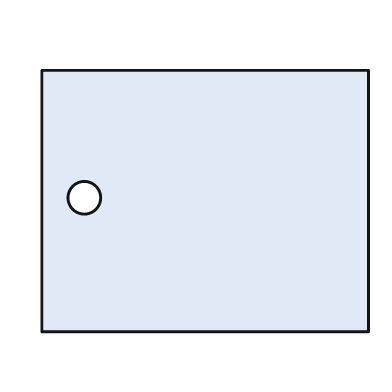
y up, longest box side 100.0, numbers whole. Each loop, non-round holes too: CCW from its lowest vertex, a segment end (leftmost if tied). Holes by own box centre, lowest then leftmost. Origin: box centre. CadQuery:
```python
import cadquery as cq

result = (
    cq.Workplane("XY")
    .moveTo(-50.0, -40.0)
    .lineTo(50.0, -40.0)
    .lineTo(50.0, 40.0)
    .lineTo(-50.0, 40.0)
    .close()
    .moveTo(-37.0, 1.0)
    .circle(5.0)
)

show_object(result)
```